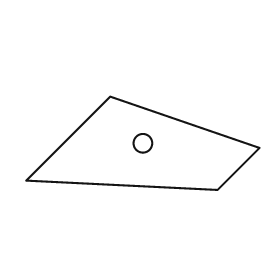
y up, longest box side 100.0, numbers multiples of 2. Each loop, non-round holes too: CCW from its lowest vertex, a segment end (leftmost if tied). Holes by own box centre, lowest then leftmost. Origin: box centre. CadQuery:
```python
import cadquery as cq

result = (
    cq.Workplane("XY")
    .moveTo(32.0, -20.0)
    .lineTo(50.0, -2.0)
    .lineTo(-14.0, 20.0)
    .lineTo(-50.0, -16.0)
    .close()
    .moveTo(0.0, 0.0)
    .circle(4.0)
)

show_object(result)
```